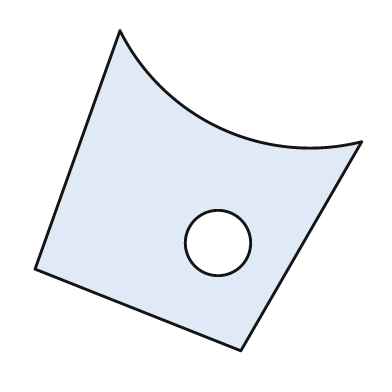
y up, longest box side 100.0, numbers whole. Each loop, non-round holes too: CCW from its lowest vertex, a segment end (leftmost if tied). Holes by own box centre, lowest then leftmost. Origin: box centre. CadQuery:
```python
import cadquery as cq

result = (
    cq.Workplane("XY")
    .moveTo(13.0, -49.0)
    .lineTo(50.0, 15.0)
    .threePointArc((7.0, 19.0), (-24.0, 49.0))
    .lineTo(-50.0, -24.0)
    .close()
    .moveTo(6.0, -16.0)
    .circle(10.0)
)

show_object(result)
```